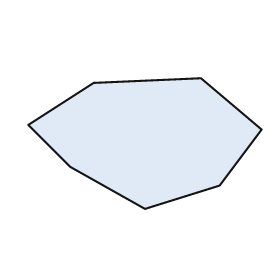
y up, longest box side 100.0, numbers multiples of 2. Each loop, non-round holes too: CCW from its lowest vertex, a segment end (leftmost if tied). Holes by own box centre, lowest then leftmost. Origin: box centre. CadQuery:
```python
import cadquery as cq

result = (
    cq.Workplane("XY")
    .moveTo(0.0, -28.0)
    .lineTo(32.0, -18.0)
    .lineTo(50.0, 6.0)
    .lineTo(24.0, 28.0)
    .lineTo(-22.0, 26.0)
    .lineTo(-50.0, 8.0)
    .lineTo(-32.0, -10.0)
    .close()
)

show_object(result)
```